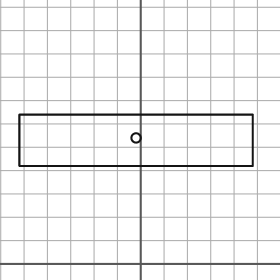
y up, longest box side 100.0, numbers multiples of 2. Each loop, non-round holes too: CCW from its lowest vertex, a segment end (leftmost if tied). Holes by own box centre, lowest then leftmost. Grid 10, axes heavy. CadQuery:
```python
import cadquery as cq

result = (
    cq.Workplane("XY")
    .moveTo(-52.0, 42.0)
    .lineTo(48.0, 42.0)
    .lineTo(48.0, 64.0)
    .lineTo(-52.0, 64.0)
    .close()
    .moveTo(-2.0, 54.0)
    .circle(2.0)
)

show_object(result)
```